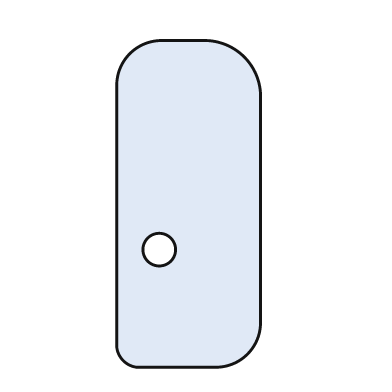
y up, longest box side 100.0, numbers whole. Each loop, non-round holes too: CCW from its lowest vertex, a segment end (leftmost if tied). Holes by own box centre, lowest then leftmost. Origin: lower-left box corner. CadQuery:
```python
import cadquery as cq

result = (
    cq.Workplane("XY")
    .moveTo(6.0, 0.0)
    .lineTo(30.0, 0.0)
    .threePointArc((40.0, 4.0), (44.0, 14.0))
    .lineTo(44.0, 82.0)
    .threePointArc((39.0, 95.0), (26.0, 100.0))
    .lineTo(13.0, 100.0)
    .threePointArc((4.0, 96.0), (0.0, 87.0))
    .lineTo(0.0, 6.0)
    .threePointArc((2.0, 2.0), (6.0, 0.0))
    .close()
    .moveTo(13.0, 36.0)
    .circle(5.0)
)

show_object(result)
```